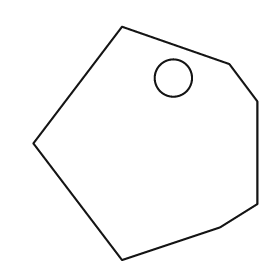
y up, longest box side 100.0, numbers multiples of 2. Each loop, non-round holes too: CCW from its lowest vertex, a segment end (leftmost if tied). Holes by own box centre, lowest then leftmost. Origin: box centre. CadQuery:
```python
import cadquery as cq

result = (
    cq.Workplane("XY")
    .moveTo(-10.0, -50.0)
    .lineTo(32.0, -36.0)
    .lineTo(48.0, -26.0)
    .lineTo(48.0, 18.0)
    .lineTo(36.0, 34.0)
    .lineTo(-10.0, 50.0)
    .lineTo(-48.0, 0.0)
    .close()
    .moveTo(12.0, 28.0)
    .circle(8.0)
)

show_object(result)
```